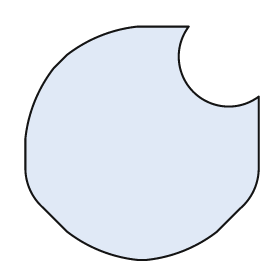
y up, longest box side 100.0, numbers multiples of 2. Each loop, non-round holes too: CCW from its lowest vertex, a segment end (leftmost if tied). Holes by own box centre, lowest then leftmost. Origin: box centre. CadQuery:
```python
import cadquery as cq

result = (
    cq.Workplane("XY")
    .moveTo(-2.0, -50.0)
    .lineTo(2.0, -50.0)
    .threePointArc((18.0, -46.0), (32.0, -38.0))
    .lineTo(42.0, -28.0)
    .threePointArc((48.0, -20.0), (50.0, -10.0))
    .lineTo(50.0, 20.0)
    .threePointArc((22.0, 22.0), (20.0, 50.0))
    .lineTo(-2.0, 50.0)
    .threePointArc((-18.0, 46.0), (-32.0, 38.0))
    .lineTo(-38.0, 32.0)
    .threePointArc((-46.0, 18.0), (-50.0, 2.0))
    .lineTo(-50.0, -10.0)
    .threePointArc((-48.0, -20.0), (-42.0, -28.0))
    .lineTo(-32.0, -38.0)
    .threePointArc((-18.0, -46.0), (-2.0, -50.0))
    .close()
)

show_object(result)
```